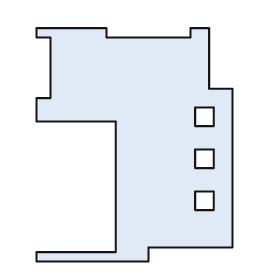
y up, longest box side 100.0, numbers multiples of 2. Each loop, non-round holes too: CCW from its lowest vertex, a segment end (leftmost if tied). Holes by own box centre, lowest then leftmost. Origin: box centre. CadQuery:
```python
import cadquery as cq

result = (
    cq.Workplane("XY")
    .moveTo(-42.0, -50.0)
    .lineTo(6.0, -50.0)
    .lineTo(6.0, -44.0)
    .lineTo(42.0, -44.0)
    .lineTo(42.0, 24.0)
    .lineTo(32.0, 24.0)
    .lineTo(32.0, 50.0)
    .lineTo(24.0, 50.0)
    .lineTo(24.0, 46.0)
    .lineTo(-12.0, 46.0)
    .lineTo(-12.0, 50.0)
    .lineTo(-42.0, 50.0)
    .lineTo(-42.0, 46.0)
    .lineTo(-36.0, 46.0)
    .lineTo(-36.0, 20.0)
    .lineTo(-42.0, 20.0)
    .lineTo(-42.0, 10.0)
    .lineTo(-8.0, 10.0)
    .lineTo(-8.0, -46.0)
    .lineTo(-42.0, -46.0)
    .close()
    .moveTo(26.0, -28.0)
    .lineTo(34.0, -28.0)
    .lineTo(34.0, -20.0)
    .lineTo(26.0, -20.0)
    .close()
    .moveTo(26.0, -10.0)
    .lineTo(34.0, -10.0)
    .lineTo(34.0, -2.0)
    .lineTo(26.0, -2.0)
    .close()
    .moveTo(26.0, 8.0)
    .lineTo(34.0, 8.0)
    .lineTo(34.0, 16.0)
    .lineTo(26.0, 16.0)
    .close()
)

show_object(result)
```